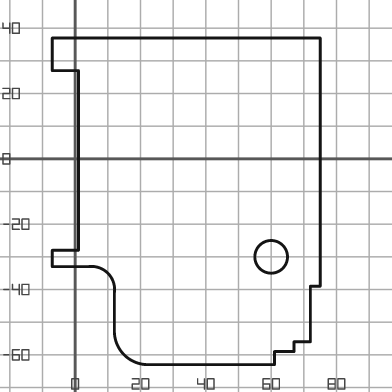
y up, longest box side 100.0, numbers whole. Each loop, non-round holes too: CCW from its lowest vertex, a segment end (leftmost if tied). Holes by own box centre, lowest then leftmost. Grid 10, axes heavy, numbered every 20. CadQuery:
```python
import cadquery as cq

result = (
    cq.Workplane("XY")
    .moveTo(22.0, -63.0)
    .lineTo(61.0, -63.0)
    .lineTo(61.0, -59.0)
    .lineTo(67.0, -59.0)
    .lineTo(67.0, -56.0)
    .lineTo(72.0, -56.0)
    .lineTo(72.0, -39.0)
    .lineTo(75.0, -39.0)
    .lineTo(75.0, 37.0)
    .lineTo(-7.0, 37.0)
    .lineTo(-7.0, 27.0)
    .lineTo(1.0, 27.0)
    .lineTo(1.0, -28.0)
    .lineTo(-7.0, -28.0)
    .lineTo(-7.0, -33.0)
    .lineTo(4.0, -33.0)
    .threePointArc((10.0, -35.0), (12.0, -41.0))
    .lineTo(12.0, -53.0)
    .threePointArc((15.0, -60.0), (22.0, -63.0))
    .close()
    .moveTo(60.0, -30.0)
    .circle(5.0)
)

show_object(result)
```